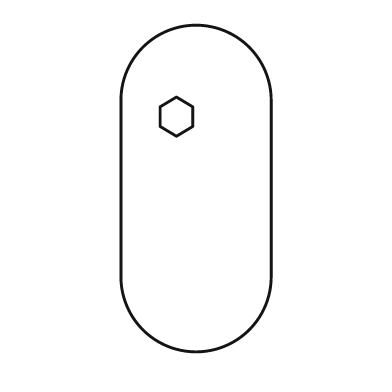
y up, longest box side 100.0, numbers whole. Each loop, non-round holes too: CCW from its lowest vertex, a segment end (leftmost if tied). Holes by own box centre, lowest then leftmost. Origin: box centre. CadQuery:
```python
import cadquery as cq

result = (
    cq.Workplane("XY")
    .moveTo(-23.0, -27.0)
    .threePointArc((0.0, -50.0), (23.0, -27.0))
    .lineTo(23.0, 27.0)
    .threePointArc((0.0, 50.0), (-23.0, 27.0))
    .close()
    .moveTo(-6.0, 16.0)
    .lineTo(-1.0, 19.0)
    .lineTo(-1.0, 25.0)
    .lineTo(-6.0, 28.0)
    .lineTo(-11.0, 25.0)
    .lineTo(-11.0, 19.0)
    .close()
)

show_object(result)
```